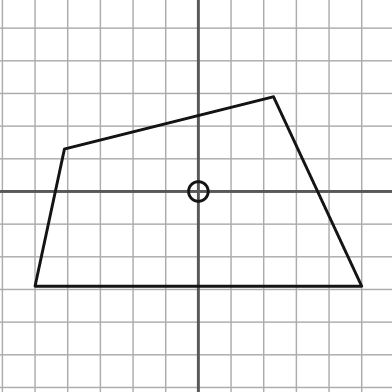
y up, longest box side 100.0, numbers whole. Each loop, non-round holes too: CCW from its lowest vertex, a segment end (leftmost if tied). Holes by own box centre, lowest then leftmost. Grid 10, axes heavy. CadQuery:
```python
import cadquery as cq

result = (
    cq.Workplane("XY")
    .moveTo(-50.0, -29.0)
    .lineTo(50.0, -29.0)
    .lineTo(23.0, 29.0)
    .lineTo(-41.0, 13.0)
    .close()
    .moveTo(0.0, 0.0)
    .circle(3.0)
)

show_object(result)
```